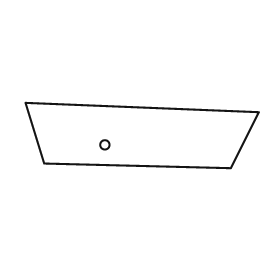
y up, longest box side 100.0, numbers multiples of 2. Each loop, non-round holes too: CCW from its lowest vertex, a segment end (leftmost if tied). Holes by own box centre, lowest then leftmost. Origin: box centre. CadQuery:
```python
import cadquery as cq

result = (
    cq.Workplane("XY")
    .moveTo(38.0, -14.0)
    .lineTo(50.0, 10.0)
    .lineTo(-50.0, 14.0)
    .lineTo(-42.0, -12.0)
    .close()
    .moveTo(-16.0, -4.0)
    .circle(2.0)
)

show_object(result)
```